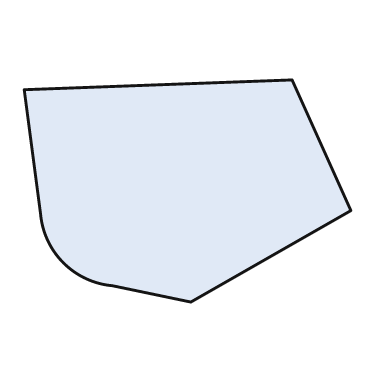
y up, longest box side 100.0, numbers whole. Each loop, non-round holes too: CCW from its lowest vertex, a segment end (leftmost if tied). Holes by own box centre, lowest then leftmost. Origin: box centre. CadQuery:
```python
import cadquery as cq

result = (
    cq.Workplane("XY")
    .moveTo(1.0, -34.0)
    .lineTo(50.0, -6.0)
    .lineTo(32.0, 34.0)
    .lineTo(-50.0, 31.0)
    .lineTo(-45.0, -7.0)
    .threePointArc((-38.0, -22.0), (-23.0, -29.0))
    .close()
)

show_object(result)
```